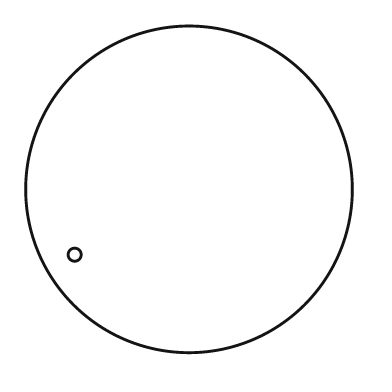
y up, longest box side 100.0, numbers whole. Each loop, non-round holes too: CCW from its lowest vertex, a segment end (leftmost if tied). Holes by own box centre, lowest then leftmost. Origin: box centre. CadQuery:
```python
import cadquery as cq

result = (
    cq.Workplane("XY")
    .moveTo(0.0, 0.0)
    .circle(50.0)
    .moveTo(-35.0, -20.0)
    .circle(2.0)
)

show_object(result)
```